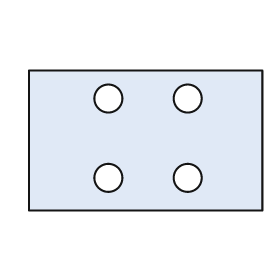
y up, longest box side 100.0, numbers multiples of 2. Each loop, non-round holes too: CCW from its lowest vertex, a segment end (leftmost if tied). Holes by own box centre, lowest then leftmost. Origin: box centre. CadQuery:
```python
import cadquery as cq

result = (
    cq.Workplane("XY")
    .moveTo(-50.0, -30.0)
    .lineTo(50.0, -30.0)
    .lineTo(50.0, 30.0)
    .lineTo(-50.0, 30.0)
    .close()
    .moveTo(-16.0, -16.0)
    .circle(6.0)
    .moveTo(18.0, -16.0)
    .circle(6.0)
    .moveTo(-16.0, 18.0)
    .circle(6.0)
    .moveTo(18.0, 18.0)
    .circle(6.0)
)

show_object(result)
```